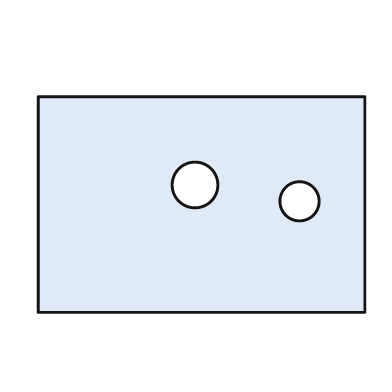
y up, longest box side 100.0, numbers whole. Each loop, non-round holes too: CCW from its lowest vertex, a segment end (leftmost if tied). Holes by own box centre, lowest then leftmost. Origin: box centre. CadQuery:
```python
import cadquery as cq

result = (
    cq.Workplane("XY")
    .moveTo(-50.0, -33.0)
    .lineTo(50.0, -33.0)
    .lineTo(50.0, 33.0)
    .lineTo(-50.0, 33.0)
    .close()
    .moveTo(30.0, 1.0)
    .circle(6.0)
    .moveTo(-2.0, 6.0)
    .circle(7.0)
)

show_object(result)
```